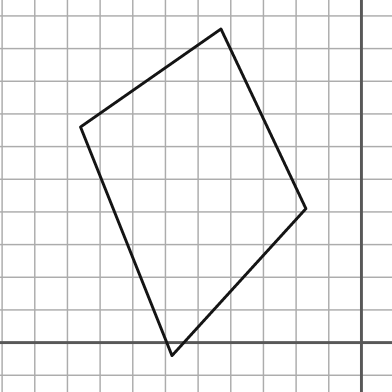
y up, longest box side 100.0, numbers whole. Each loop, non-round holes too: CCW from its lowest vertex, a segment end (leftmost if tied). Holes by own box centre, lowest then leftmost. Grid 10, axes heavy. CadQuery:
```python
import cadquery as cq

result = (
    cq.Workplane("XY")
    .moveTo(-58.0, -4.0)
    .lineTo(-17.0, 41.0)
    .lineTo(-43.0, 96.0)
    .lineTo(-86.0, 66.0)
    .close()
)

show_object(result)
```